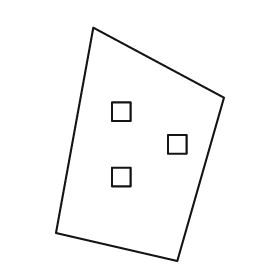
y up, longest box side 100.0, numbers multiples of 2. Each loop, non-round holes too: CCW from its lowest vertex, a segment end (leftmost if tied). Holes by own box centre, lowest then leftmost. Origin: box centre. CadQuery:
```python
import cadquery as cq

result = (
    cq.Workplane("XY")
    .moveTo(16.0, -50.0)
    .lineTo(36.0, 20.0)
    .lineTo(-20.0, 50.0)
    .lineTo(-36.0, -38.0)
    .close()
    .moveTo(-12.0, -18.0)
    .lineTo(-4.0, -18.0)
    .lineTo(-4.0, -10.0)
    .lineTo(-12.0, -10.0)
    .close()
    .moveTo(12.0, -4.0)
    .lineTo(20.0, -4.0)
    .lineTo(20.0, 4.0)
    .lineTo(12.0, 4.0)
    .close()
    .moveTo(-12.0, 10.0)
    .lineTo(-4.0, 10.0)
    .lineTo(-4.0, 18.0)
    .lineTo(-12.0, 18.0)
    .close()
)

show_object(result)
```